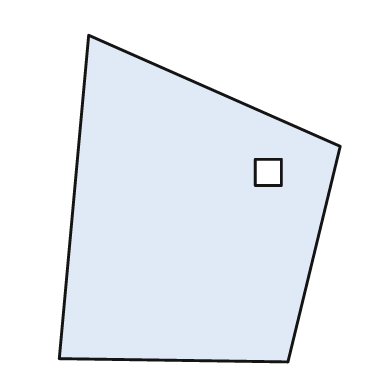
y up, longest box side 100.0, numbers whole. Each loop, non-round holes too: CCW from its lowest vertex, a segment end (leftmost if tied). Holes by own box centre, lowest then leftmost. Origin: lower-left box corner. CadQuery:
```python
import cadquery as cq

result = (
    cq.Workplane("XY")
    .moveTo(70.0, 0.0)
    .lineTo(86.0, 66.0)
    .lineTo(9.0, 100.0)
    .lineTo(0.0, 1.0)
    .close()
    .moveTo(60.0, 54.0)
    .lineTo(68.0, 54.0)
    .lineTo(68.0, 62.0)
    .lineTo(60.0, 62.0)
    .close()
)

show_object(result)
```